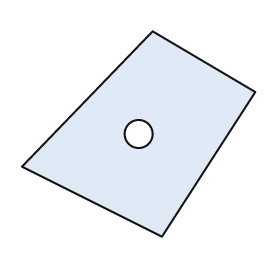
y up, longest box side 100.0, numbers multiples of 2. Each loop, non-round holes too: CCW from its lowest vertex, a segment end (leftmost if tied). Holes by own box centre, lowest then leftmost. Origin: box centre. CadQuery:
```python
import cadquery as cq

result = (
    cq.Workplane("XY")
    .moveTo(10.0, -44.0)
    .lineTo(50.0, 18.0)
    .lineTo(6.0, 44.0)
    .lineTo(-50.0, -14.0)
    .close()
    .moveTo(0.0, 0.0)
    .circle(6.0)
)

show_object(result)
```